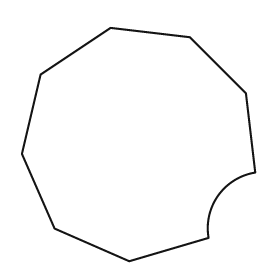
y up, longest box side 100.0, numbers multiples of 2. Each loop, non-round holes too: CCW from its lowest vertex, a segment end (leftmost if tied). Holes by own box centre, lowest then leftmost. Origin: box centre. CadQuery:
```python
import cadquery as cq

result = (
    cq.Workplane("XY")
    .moveTo(-4.0, -50.0)
    .lineTo(30.0, -40.0)
    .threePointArc((34.0, -22.0), (50.0, -12.0))
    .lineTo(46.0, 22.0)
    .lineTo(22.0, 46.0)
    .lineTo(-12.0, 50.0)
    .lineTo(-42.0, 30.0)
    .lineTo(-50.0, -4.0)
    .lineTo(-36.0, -36.0)
    .close()
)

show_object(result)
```